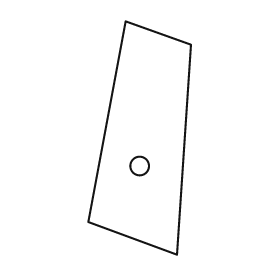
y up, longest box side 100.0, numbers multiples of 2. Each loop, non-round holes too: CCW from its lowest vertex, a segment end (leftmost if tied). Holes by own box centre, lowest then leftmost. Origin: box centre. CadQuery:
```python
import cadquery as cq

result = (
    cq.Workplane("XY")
    .moveTo(16.0, -50.0)
    .lineTo(22.0, 40.0)
    .lineTo(-6.0, 50.0)
    .lineTo(-22.0, -36.0)
    .close()
    .moveTo(0.0, -12.0)
    .circle(4.0)
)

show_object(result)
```